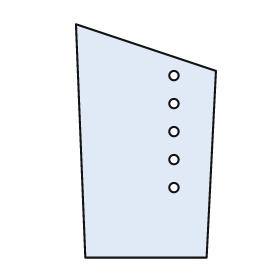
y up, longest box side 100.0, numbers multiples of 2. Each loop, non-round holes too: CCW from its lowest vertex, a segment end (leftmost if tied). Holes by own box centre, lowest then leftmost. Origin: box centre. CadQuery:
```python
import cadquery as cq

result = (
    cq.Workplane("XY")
    .moveTo(-26.0, -50.0)
    .lineTo(26.0, -50.0)
    .lineTo(30.0, 30.0)
    .lineTo(-30.0, 50.0)
    .close()
    .moveTo(12.0, -20.0)
    .circle(2.0)
    .moveTo(12.0, -8.0)
    .circle(2.0)
    .moveTo(12.0, 4.0)
    .circle(2.0)
    .moveTo(12.0, 16.0)
    .circle(2.0)
    .moveTo(12.0, 28.0)
    .circle(2.0)
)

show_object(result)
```